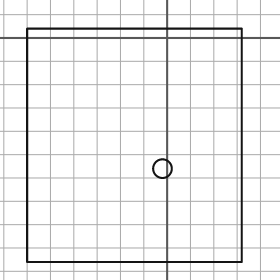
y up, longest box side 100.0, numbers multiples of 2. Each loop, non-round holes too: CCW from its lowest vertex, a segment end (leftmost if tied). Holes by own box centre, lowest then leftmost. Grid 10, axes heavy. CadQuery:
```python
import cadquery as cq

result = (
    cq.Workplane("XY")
    .moveTo(-60.0, -96.0)
    .lineTo(32.0, -96.0)
    .lineTo(32.0, 4.0)
    .lineTo(-60.0, 4.0)
    .close()
    .moveTo(-2.0, -56.0)
    .circle(4.0)
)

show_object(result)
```